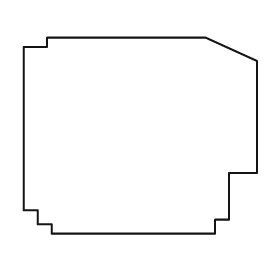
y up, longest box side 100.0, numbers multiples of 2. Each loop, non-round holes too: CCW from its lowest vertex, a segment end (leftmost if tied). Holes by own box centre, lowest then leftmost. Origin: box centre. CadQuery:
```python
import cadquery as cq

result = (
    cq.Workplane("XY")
    .moveTo(-38.0, -42.0)
    .lineTo(32.0, -42.0)
    .lineTo(32.0, -36.0)
    .lineTo(38.0, -36.0)
    .lineTo(38.0, -16.0)
    .lineTo(50.0, -16.0)
    .lineTo(50.0, 32.0)
    .lineTo(28.0, 42.0)
    .lineTo(-40.0, 42.0)
    .lineTo(-40.0, 38.0)
    .lineTo(-50.0, 38.0)
    .lineTo(-50.0, -32.0)
    .lineTo(-44.0, -32.0)
    .lineTo(-44.0, -38.0)
    .lineTo(-38.0, -38.0)
    .close()
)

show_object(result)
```